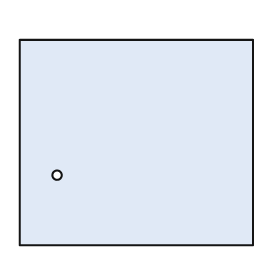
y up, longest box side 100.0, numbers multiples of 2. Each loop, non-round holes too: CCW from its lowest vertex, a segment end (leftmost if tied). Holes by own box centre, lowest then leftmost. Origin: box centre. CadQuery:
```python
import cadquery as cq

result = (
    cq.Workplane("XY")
    .moveTo(-50.0, -44.0)
    .lineTo(50.0, -44.0)
    .lineTo(50.0, 44.0)
    .lineTo(-50.0, 44.0)
    .close()
    .moveTo(-34.0, -14.0)
    .circle(2.0)
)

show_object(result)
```